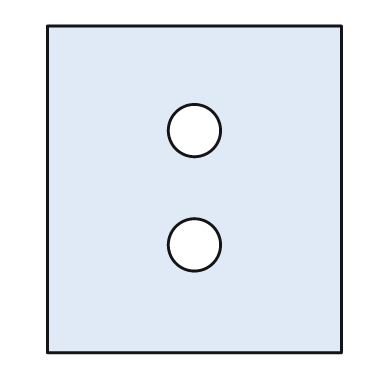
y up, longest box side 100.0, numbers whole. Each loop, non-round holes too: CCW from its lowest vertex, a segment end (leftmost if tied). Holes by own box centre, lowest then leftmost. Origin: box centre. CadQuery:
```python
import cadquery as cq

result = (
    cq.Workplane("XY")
    .moveTo(-45.0, -50.0)
    .lineTo(45.0, -50.0)
    .lineTo(45.0, 50.0)
    .lineTo(-45.0, 50.0)
    .close()
    .moveTo(0.0, -17.0)
    .circle(8.0)
    .moveTo(0.0, 18.0)
    .circle(8.0)
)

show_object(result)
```